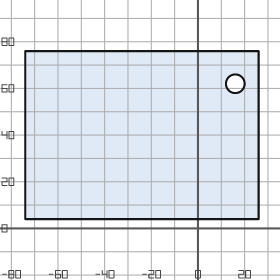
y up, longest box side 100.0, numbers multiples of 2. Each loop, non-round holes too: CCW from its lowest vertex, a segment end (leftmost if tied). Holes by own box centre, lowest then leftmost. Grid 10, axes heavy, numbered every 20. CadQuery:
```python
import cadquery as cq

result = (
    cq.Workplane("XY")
    .moveTo(-74.0, 4.0)
    .lineTo(26.0, 4.0)
    .lineTo(26.0, 76.0)
    .lineTo(-74.0, 76.0)
    .close()
    .moveTo(16.0, 62.0)
    .circle(4.0)
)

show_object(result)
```